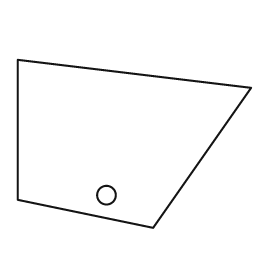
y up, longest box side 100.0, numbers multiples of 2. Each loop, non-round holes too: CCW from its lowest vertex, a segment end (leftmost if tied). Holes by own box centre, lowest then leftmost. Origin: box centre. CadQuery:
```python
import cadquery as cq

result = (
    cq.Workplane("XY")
    .moveTo(8.0, -36.0)
    .lineTo(50.0, 24.0)
    .lineTo(-50.0, 36.0)
    .lineTo(-50.0, -24.0)
    .close()
    .moveTo(-12.0, -22.0)
    .circle(4.0)
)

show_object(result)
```